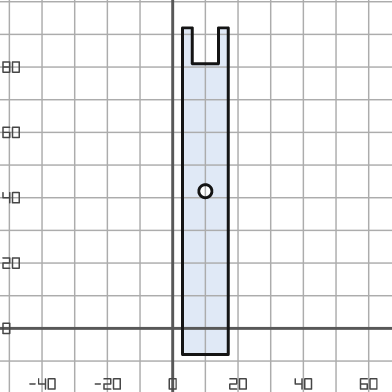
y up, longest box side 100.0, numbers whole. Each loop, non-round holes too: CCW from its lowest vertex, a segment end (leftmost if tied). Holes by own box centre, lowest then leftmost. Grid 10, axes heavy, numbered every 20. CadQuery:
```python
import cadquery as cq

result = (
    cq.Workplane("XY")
    .moveTo(3.0, -8.0)
    .lineTo(17.0, -8.0)
    .lineTo(17.0, 92.0)
    .lineTo(14.0, 92.0)
    .lineTo(14.0, 81.0)
    .lineTo(6.0, 81.0)
    .lineTo(6.0, 92.0)
    .lineTo(3.0, 92.0)
    .close()
    .moveTo(10.0, 42.0)
    .circle(2.0)
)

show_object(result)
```